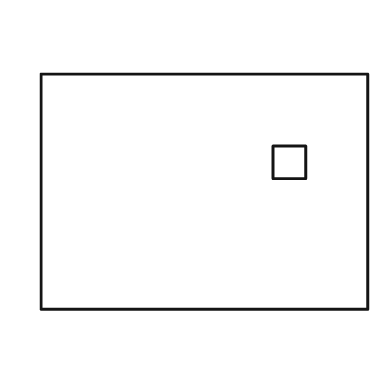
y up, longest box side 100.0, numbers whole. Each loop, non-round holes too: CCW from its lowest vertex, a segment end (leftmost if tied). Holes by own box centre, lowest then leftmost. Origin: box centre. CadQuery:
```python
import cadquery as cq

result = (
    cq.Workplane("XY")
    .moveTo(-50.0, -36.0)
    .lineTo(50.0, -36.0)
    .lineTo(50.0, 36.0)
    .lineTo(-50.0, 36.0)
    .close()
    .moveTo(21.0, 4.0)
    .lineTo(31.0, 4.0)
    .lineTo(31.0, 14.0)
    .lineTo(21.0, 14.0)
    .close()
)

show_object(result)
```